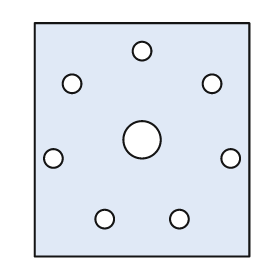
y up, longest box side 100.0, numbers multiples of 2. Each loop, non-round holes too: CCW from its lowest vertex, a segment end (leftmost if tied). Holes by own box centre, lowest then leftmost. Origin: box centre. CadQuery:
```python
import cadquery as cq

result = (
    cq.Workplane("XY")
    .moveTo(-46.0, -50.0)
    .lineTo(46.0, -50.0)
    .lineTo(46.0, 50.0)
    .lineTo(-46.0, 50.0)
    .close()
    .moveTo(-16.0, -34.0)
    .circle(4.0)
    .moveTo(16.0, -34.0)
    .circle(4.0)
    .moveTo(-38.0, -8.0)
    .circle(4.0)
    .moveTo(38.0, -8.0)
    .circle(4.0)
    .moveTo(0.0, 0.0)
    .circle(8.0)
    .moveTo(-30.0, 24.0)
    .circle(4.0)
    .moveTo(30.0, 24.0)
    .circle(4.0)
    .moveTo(0.0, 38.0)
    .circle(4.0)
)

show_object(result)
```